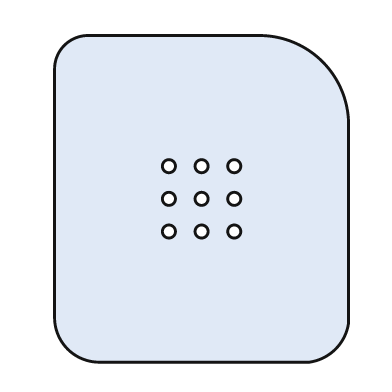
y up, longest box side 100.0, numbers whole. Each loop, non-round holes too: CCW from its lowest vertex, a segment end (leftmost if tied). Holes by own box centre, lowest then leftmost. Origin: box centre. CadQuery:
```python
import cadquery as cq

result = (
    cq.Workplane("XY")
    .moveTo(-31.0, -50.0)
    .lineTo(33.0, -50.0)
    .threePointArc((41.0, -46.0), (45.0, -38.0))
    .lineTo(45.0, 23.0)
    .threePointArc((37.0, 42.0), (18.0, 50.0))
    .lineTo(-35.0, 50.0)
    .threePointArc((-42.0, 47.0), (-45.0, 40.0))
    .lineTo(-45.0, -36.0)
    .threePointArc((-41.0, -46.0), (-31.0, -50.0))
    .close()
    .moveTo(-10.0, -10.0)
    .circle(2.0)
    .moveTo(0.0, -10.0)
    .circle(2.0)
    .moveTo(10.0, -10.0)
    .circle(2.0)
    .moveTo(-10.0, 0.0)
    .circle(2.0)
    .moveTo(0.0, 0.0)
    .circle(2.0)
    .moveTo(10.0, 0.0)
    .circle(2.0)
    .moveTo(-10.0, 10.0)
    .circle(2.0)
    .moveTo(0.0, 10.0)
    .circle(2.0)
    .moveTo(10.0, 10.0)
    .circle(2.0)
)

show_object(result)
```